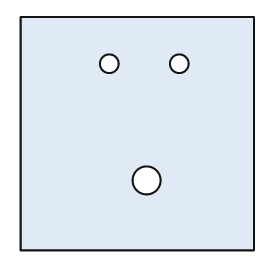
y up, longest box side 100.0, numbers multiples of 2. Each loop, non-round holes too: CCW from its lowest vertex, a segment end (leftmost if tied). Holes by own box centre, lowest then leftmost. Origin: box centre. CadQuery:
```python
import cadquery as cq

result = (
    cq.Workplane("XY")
    .moveTo(-50.0, -50.0)
    .lineTo(50.0, -50.0)
    .lineTo(50.0, 50.0)
    .lineTo(-50.0, 50.0)
    .close()
    .moveTo(4.0, -20.0)
    .circle(6.0)
    .moveTo(-12.0, 30.0)
    .circle(4.0)
    .moveTo(18.0, 30.0)
    .circle(4.0)
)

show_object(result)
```